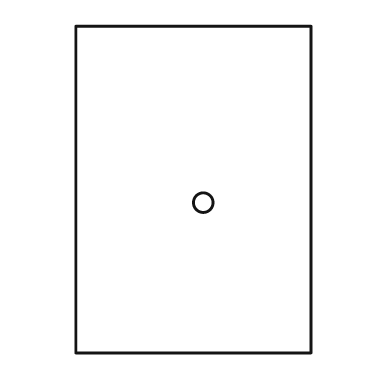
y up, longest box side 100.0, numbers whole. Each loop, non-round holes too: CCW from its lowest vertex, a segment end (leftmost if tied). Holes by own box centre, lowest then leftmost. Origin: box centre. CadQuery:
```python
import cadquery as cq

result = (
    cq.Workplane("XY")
    .moveTo(-36.0, -50.0)
    .lineTo(36.0, -50.0)
    .lineTo(36.0, 50.0)
    .lineTo(-36.0, 50.0)
    .close()
    .moveTo(3.0, -4.0)
    .circle(3.0)
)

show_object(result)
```